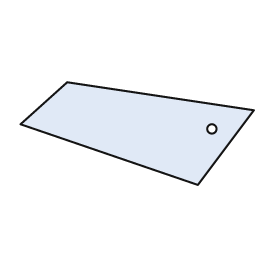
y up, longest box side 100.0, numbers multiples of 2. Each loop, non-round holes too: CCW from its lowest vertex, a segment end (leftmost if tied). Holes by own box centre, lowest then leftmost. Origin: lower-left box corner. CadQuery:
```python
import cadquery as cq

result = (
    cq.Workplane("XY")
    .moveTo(76.0, 0.0)
    .lineTo(100.0, 32.0)
    .lineTo(20.0, 44.0)
    .lineTo(0.0, 26.0)
    .close()
    .moveTo(82.0, 24.0)
    .circle(2.0)
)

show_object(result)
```